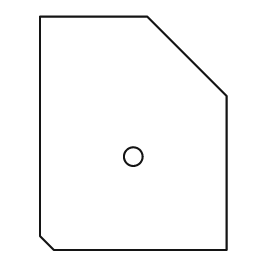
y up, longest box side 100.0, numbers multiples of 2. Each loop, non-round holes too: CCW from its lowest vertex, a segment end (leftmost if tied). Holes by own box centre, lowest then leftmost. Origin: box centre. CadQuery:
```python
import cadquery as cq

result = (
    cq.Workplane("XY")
    .moveTo(-34.0, -50.0)
    .lineTo(40.0, -50.0)
    .lineTo(40.0, 16.0)
    .lineTo(6.0, 50.0)
    .lineTo(-40.0, 50.0)
    .lineTo(-40.0, -44.0)
    .close()
    .moveTo(0.0, -10.0)
    .circle(4.0)
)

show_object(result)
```